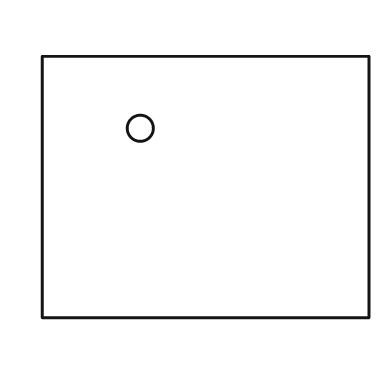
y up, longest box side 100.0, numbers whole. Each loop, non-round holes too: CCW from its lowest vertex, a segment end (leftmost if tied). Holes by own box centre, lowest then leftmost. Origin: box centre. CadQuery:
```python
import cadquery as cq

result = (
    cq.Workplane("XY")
    .moveTo(-50.0, -40.0)
    .lineTo(50.0, -40.0)
    .lineTo(50.0, 40.0)
    .lineTo(-50.0, 40.0)
    .close()
    .moveTo(-20.0, 18.0)
    .circle(4.0)
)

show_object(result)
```